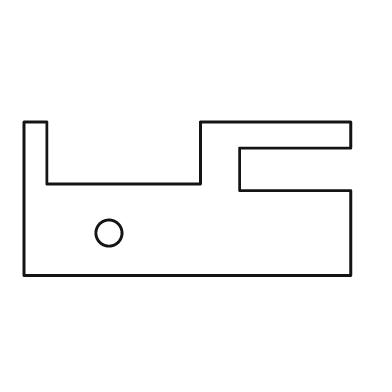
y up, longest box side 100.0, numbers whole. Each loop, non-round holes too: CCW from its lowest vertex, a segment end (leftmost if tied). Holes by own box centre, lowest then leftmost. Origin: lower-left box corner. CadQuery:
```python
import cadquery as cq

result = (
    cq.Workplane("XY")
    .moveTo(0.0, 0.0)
    .lineTo(100.0, 0.0)
    .lineTo(100.0, 26.0)
    .lineTo(66.0, 26.0)
    .lineTo(66.0, 39.0)
    .lineTo(100.0, 39.0)
    .lineTo(100.0, 47.0)
    .lineTo(54.0, 47.0)
    .lineTo(54.0, 28.0)
    .lineTo(7.0, 28.0)
    .lineTo(7.0, 47.0)
    .lineTo(0.0, 47.0)
    .close()
    .moveTo(26.0, 13.0)
    .circle(4.0)
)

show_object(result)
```